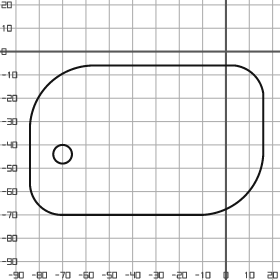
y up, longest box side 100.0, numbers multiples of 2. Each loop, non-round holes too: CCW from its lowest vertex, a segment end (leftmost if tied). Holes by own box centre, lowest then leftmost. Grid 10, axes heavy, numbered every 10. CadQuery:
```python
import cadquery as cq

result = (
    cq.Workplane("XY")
    .moveTo(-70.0, -70.0)
    .lineTo(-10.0, -70.0)
    .threePointArc((8.0, -62.0), (16.0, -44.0))
    .lineTo(16.0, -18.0)
    .threePointArc((12.0, -10.0), (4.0, -6.0))
    .lineTo(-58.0, -6.0)
    .threePointArc((-76.0, -14.0), (-84.0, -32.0))
    .lineTo(-84.0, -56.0)
    .threePointArc((-80.0, -66.0), (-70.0, -70.0))
    .close()
    .moveTo(-70.0, -44.0)
    .circle(4.0)
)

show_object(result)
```